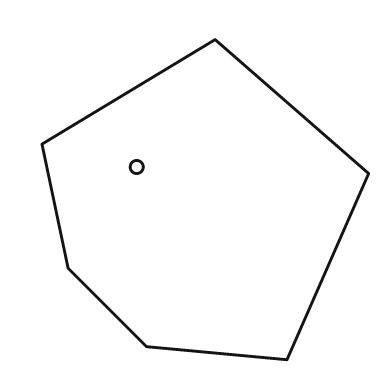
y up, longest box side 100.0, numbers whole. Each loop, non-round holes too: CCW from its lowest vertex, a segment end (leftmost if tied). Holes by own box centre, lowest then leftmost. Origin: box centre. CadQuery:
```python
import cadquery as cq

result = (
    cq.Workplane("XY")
    .moveTo(25.0, -49.0)
    .lineTo(50.0, 8.0)
    .lineTo(3.0, 49.0)
    .lineTo(-50.0, 17.0)
    .lineTo(-42.0, -21.0)
    .lineTo(-18.0, -45.0)
    .close()
    .moveTo(-21.0, 10.0)
    .circle(2.0)
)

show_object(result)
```